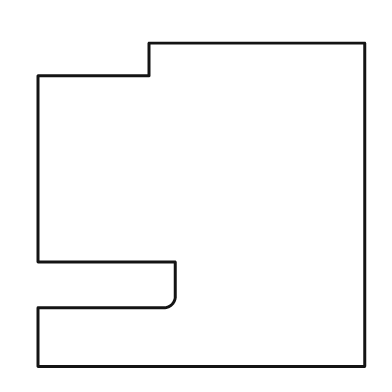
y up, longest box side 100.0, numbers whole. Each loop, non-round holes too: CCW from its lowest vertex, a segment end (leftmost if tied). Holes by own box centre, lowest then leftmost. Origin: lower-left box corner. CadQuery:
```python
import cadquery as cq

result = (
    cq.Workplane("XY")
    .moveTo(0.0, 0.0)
    .lineTo(100.0, 0.0)
    .lineTo(100.0, 99.0)
    .lineTo(34.0, 99.0)
    .lineTo(34.0, 89.0)
    .lineTo(0.0, 89.0)
    .lineTo(0.0, 32.0)
    .lineTo(42.0, 32.0)
    .lineTo(42.0, 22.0)
    .threePointArc((41.0, 19.0), (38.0, 18.0))
    .lineTo(0.0, 18.0)
    .close()
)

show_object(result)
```